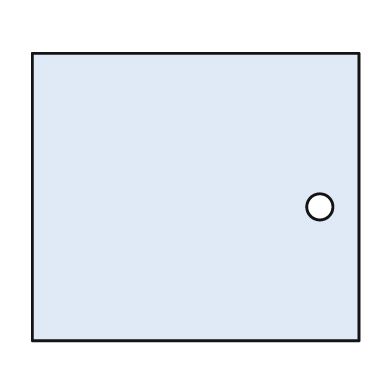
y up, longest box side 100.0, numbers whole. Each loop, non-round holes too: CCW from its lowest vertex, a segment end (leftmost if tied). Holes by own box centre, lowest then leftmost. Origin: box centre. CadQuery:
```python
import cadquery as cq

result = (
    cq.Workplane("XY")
    .moveTo(-50.0, -44.0)
    .lineTo(50.0, -44.0)
    .lineTo(50.0, 44.0)
    .lineTo(-50.0, 44.0)
    .close()
    .moveTo(38.0, -3.0)
    .circle(4.0)
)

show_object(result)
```